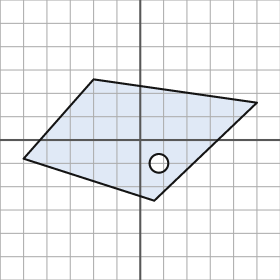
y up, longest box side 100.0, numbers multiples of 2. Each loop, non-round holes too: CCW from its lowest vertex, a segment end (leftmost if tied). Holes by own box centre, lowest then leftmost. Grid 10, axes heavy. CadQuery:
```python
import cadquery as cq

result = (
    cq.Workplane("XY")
    .moveTo(6.0, -26.0)
    .lineTo(50.0, 16.0)
    .lineTo(-20.0, 26.0)
    .lineTo(-50.0, -8.0)
    .close()
    .moveTo(8.0, -10.0)
    .circle(4.0)
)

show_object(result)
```